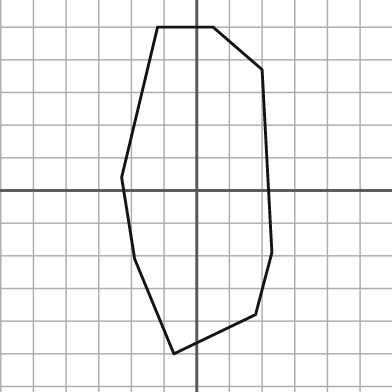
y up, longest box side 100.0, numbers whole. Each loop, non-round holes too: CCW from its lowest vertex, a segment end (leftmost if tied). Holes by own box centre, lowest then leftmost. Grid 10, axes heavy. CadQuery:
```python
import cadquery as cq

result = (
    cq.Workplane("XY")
    .moveTo(-7.0, -50.0)
    .lineTo(18.0, -38.0)
    .lineTo(23.0, -19.0)
    .lineTo(20.0, 37.0)
    .lineTo(5.0, 50.0)
    .lineTo(-12.0, 50.0)
    .lineTo(-23.0, 4.0)
    .lineTo(-19.0, -21.0)
    .close()
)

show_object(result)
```